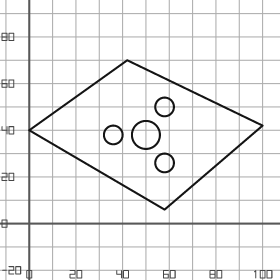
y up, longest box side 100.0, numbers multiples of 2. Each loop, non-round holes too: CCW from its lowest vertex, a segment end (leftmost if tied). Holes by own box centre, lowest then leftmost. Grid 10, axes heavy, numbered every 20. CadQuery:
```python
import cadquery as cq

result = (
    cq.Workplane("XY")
    .moveTo(58.0, 6.0)
    .lineTo(100.0, 42.0)
    .lineTo(42.0, 70.0)
    .lineTo(0.0, 40.0)
    .close()
    .moveTo(58.0, 26.0)
    .circle(4.0)
    .moveTo(36.0, 38.0)
    .circle(4.0)
    .moveTo(50.0, 38.0)
    .circle(6.0)
    .moveTo(58.0, 50.0)
    .circle(4.0)
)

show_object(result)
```